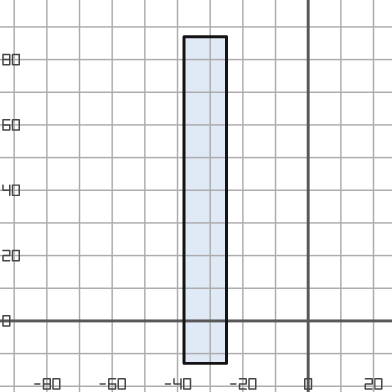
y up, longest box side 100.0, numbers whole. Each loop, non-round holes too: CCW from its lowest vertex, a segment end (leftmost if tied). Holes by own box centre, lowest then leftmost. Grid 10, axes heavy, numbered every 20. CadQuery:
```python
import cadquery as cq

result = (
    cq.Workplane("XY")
    .moveTo(-38.0, -13.0)
    .lineTo(-25.0, -13.0)
    .lineTo(-25.0, 87.0)
    .lineTo(-38.0, 87.0)
    .close()
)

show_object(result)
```